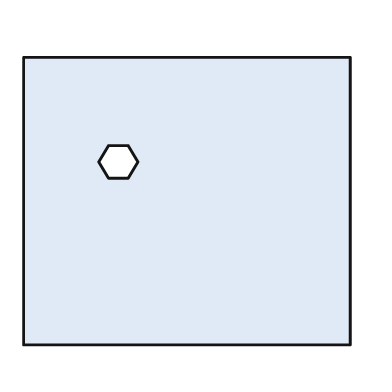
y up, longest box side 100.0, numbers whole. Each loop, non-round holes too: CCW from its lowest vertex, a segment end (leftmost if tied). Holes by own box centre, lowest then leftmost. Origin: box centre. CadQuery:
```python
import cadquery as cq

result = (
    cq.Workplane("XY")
    .moveTo(-50.0, -44.0)
    .lineTo(50.0, -44.0)
    .lineTo(50.0, 44.0)
    .lineTo(-50.0, 44.0)
    .close()
    .moveTo(-24.0, 7.0)
    .lineTo(-18.0, 7.0)
    .lineTo(-15.0, 12.0)
    .lineTo(-18.0, 17.0)
    .lineTo(-24.0, 17.0)
    .lineTo(-27.0, 12.0)
    .close()
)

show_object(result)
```